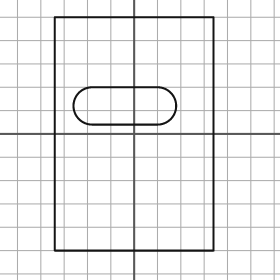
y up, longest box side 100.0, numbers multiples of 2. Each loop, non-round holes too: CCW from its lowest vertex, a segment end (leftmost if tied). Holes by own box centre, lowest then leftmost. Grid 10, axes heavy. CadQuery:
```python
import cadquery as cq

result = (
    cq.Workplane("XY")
    .moveTo(-34.0, -50.0)
    .lineTo(34.0, -50.0)
    .lineTo(34.0, 50.0)
    .lineTo(-34.0, 50.0)
    .close()
    .moveTo(-18.0, 4.0)
    .lineTo(10.0, 4.0)
    .threePointArc((18.0, 12.0), (10.0, 20.0))
    .lineTo(-18.0, 20.0)
    .threePointArc((-26.0, 12.0), (-18.0, 4.0))
    .close()
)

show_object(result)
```